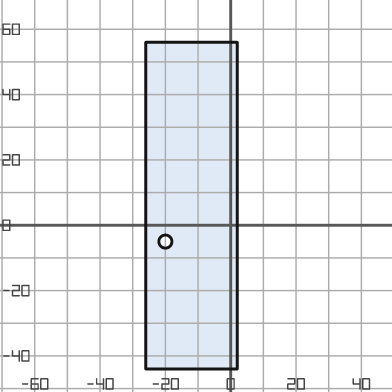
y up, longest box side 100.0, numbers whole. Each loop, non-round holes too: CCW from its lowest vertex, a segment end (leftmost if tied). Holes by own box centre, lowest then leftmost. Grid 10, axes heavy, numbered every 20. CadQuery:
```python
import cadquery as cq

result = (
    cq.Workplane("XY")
    .moveTo(-26.0, -44.0)
    .lineTo(2.0, -44.0)
    .lineTo(2.0, 56.0)
    .lineTo(-26.0, 56.0)
    .close()
    .moveTo(-20.0, -5.0)
    .circle(2.0)
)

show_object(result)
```